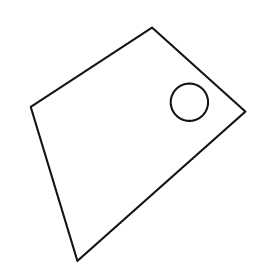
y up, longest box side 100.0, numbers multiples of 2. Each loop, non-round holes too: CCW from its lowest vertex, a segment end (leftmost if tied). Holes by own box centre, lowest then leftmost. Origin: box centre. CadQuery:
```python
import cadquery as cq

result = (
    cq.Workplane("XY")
    .moveTo(-26.0, -50.0)
    .lineTo(46.0, 14.0)
    .lineTo(6.0, 50.0)
    .lineTo(-46.0, 16.0)
    .close()
    .moveTo(22.0, 18.0)
    .circle(8.0)
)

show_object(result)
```